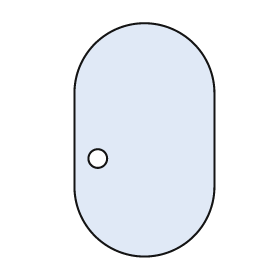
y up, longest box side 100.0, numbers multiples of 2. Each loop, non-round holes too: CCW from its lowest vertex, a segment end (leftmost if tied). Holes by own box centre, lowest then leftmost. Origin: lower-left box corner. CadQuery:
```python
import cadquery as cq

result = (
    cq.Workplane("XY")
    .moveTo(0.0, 30.0)
    .threePointArc((30.0, 0.0), (60.0, 30.0))
    .lineTo(60.0, 70.0)
    .threePointArc((30.0, 100.0), (0.0, 70.0))
    .close()
    .moveTo(10.0, 42.0)
    .circle(4.0)
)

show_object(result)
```